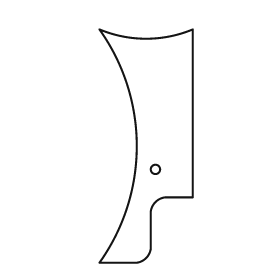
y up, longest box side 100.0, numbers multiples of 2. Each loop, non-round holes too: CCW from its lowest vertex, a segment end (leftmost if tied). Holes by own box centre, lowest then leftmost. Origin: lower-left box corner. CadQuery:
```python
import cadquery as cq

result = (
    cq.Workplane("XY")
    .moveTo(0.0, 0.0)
    .lineTo(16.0, 0.0)
    .threePointArc((20.0, 2.0), (22.0, 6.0))
    .lineTo(22.0, 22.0)
    .threePointArc((24.0, 26.0), (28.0, 28.0))
    .lineTo(40.0, 28.0)
    .lineTo(40.0, 100.0)
    .threePointArc((20.0, 96.0), (0.0, 100.0))
    .threePointArc((16.0, 50.0), (0.0, 0.0))
    .close()
    .moveTo(24.0, 40.0)
    .circle(2.0)
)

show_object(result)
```